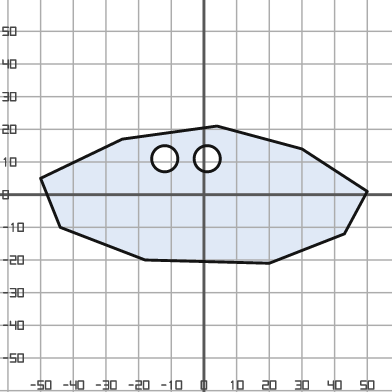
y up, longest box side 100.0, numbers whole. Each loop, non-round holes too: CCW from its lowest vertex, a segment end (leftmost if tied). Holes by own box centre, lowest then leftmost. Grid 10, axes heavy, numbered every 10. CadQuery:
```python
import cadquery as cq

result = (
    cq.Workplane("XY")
    .moveTo(20.0, -21.0)
    .lineTo(43.0, -12.0)
    .lineTo(50.0, 1.0)
    .lineTo(30.0, 14.0)
    .lineTo(4.0, 21.0)
    .lineTo(-25.0, 17.0)
    .lineTo(-50.0, 5.0)
    .lineTo(-44.0, -10.0)
    .lineTo(-18.0, -20.0)
    .close()
    .moveTo(-12.0, 11.0)
    .circle(4.0)
    .moveTo(1.0, 11.0)
    .circle(4.0)
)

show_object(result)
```